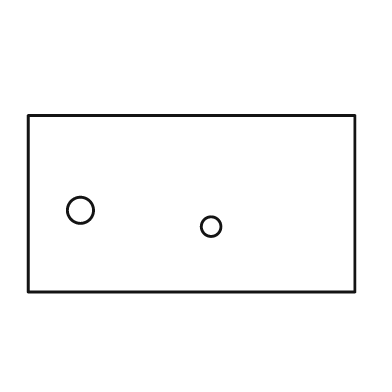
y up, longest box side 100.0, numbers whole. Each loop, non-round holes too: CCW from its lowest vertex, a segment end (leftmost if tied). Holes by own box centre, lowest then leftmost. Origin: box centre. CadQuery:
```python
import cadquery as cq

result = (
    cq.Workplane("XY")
    .moveTo(-50.0, -27.0)
    .lineTo(50.0, -27.0)
    .lineTo(50.0, 27.0)
    .lineTo(-50.0, 27.0)
    .close()
    .moveTo(6.0, -7.0)
    .circle(3.0)
    .moveTo(-34.0, -2.0)
    .circle(4.0)
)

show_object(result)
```